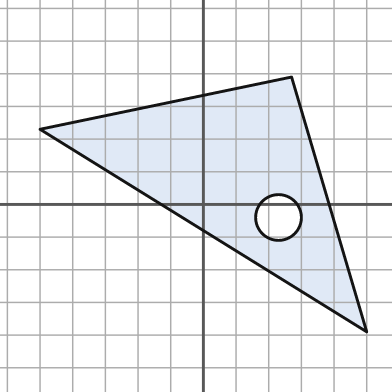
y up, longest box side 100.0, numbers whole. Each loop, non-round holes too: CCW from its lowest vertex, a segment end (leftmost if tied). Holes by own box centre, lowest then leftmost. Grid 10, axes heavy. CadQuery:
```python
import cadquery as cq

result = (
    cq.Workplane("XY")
    .moveTo(50.0, -39.0)
    .lineTo(27.0, 39.0)
    .lineTo(-50.0, 23.0)
    .close()
    .moveTo(23.0, -4.0)
    .circle(7.0)
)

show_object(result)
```